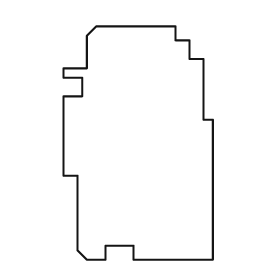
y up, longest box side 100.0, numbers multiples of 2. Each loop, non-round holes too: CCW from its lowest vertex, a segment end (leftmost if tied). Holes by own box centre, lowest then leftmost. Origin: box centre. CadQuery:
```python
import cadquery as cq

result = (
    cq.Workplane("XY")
    .moveTo(-22.0, -50.0)
    .lineTo(-14.0, -50.0)
    .lineTo(-14.0, -44.0)
    .lineTo(-2.0, -44.0)
    .lineTo(-2.0, -50.0)
    .lineTo(32.0, -50.0)
    .lineTo(32.0, 10.0)
    .lineTo(28.0, 10.0)
    .lineTo(28.0, 36.0)
    .lineTo(22.0, 36.0)
    .lineTo(22.0, 44.0)
    .lineTo(16.0, 44.0)
    .lineTo(16.0, 50.0)
    .lineTo(-18.0, 50.0)
    .lineTo(-22.0, 46.0)
    .lineTo(-22.0, 32.0)
    .lineTo(-32.0, 32.0)
    .lineTo(-32.0, 28.0)
    .lineTo(-24.0, 28.0)
    .lineTo(-24.0, 20.0)
    .lineTo(-32.0, 20.0)
    .lineTo(-32.0, -14.0)
    .lineTo(-26.0, -14.0)
    .lineTo(-26.0, -46.0)
    .close()
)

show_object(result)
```